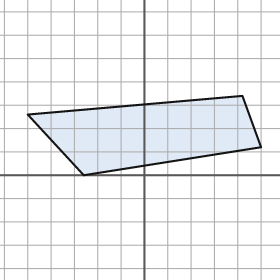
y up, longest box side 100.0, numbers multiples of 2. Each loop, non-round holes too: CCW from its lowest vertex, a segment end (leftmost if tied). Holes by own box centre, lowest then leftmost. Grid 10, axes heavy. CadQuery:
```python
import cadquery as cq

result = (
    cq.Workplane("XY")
    .moveTo(-26.0, 0.0)
    .lineTo(50.0, 12.0)
    .lineTo(42.0, 34.0)
    .lineTo(-50.0, 26.0)
    .close()
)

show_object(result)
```